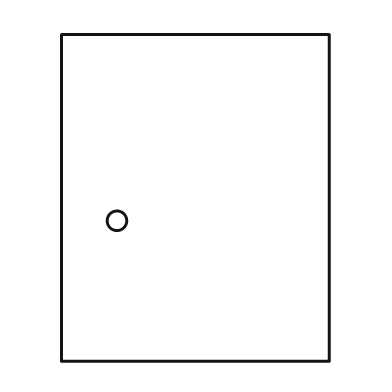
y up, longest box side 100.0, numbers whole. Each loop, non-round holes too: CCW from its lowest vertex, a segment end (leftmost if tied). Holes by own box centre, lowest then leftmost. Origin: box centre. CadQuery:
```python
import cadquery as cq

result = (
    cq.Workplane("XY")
    .moveTo(-41.0, -50.0)
    .lineTo(41.0, -50.0)
    .lineTo(41.0, 50.0)
    .lineTo(-41.0, 50.0)
    .close()
    .moveTo(-24.0, -7.0)
    .circle(3.0)
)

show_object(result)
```